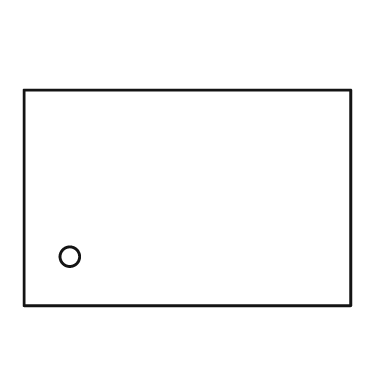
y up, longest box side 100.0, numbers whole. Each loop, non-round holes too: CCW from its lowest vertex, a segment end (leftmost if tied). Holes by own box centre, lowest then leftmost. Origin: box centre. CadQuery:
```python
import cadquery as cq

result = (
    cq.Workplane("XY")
    .moveTo(-50.0, -33.0)
    .lineTo(50.0, -33.0)
    .lineTo(50.0, 33.0)
    .lineTo(-50.0, 33.0)
    .close()
    .moveTo(-36.0, -18.0)
    .circle(3.0)
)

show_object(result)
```